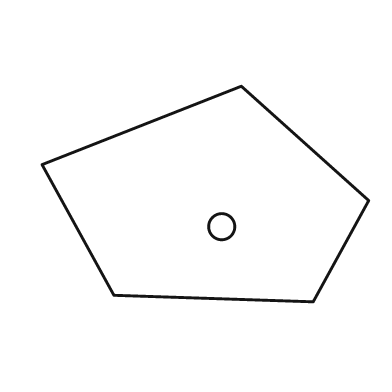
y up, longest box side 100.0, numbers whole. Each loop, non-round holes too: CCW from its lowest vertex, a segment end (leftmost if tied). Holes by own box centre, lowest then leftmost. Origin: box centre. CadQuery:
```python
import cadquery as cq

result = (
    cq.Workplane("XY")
    .moveTo(33.0, -33.0)
    .lineTo(50.0, -2.0)
    .lineTo(11.0, 33.0)
    .lineTo(-50.0, 9.0)
    .lineTo(-28.0, -31.0)
    .close()
    .moveTo(5.0, -10.0)
    .circle(4.0)
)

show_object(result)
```